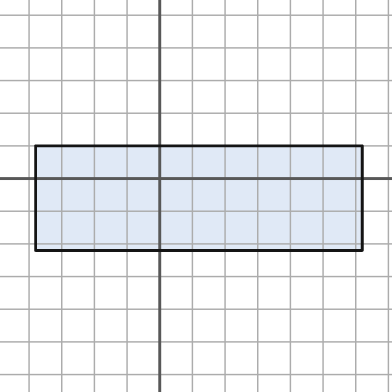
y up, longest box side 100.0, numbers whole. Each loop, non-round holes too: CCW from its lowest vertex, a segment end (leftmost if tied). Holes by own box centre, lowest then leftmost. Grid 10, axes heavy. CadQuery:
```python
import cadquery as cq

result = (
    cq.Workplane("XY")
    .moveTo(-38.0, -22.0)
    .lineTo(62.0, -22.0)
    .lineTo(62.0, 10.0)
    .lineTo(-38.0, 10.0)
    .close()
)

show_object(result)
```